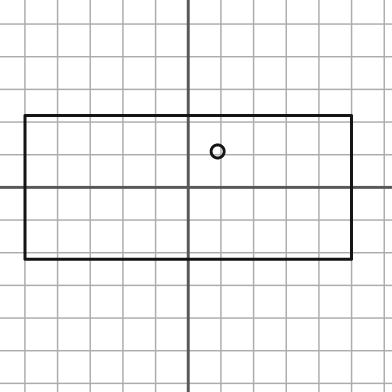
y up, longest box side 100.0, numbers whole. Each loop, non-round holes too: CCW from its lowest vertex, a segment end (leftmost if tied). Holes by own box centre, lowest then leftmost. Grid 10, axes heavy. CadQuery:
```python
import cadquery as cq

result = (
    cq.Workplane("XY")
    .moveTo(-50.0, -22.0)
    .lineTo(50.0, -22.0)
    .lineTo(50.0, 22.0)
    .lineTo(-50.0, 22.0)
    .close()
    .moveTo(9.0, 11.0)
    .circle(2.0)
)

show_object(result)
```